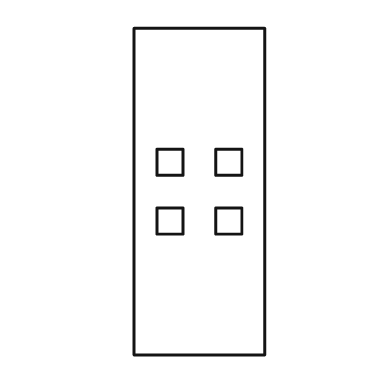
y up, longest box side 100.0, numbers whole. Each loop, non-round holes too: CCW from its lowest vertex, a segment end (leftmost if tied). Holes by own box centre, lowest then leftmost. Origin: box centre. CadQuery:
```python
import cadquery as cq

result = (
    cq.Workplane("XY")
    .moveTo(-20.0, -50.0)
    .lineTo(20.0, -50.0)
    .lineTo(20.0, 50.0)
    .lineTo(-20.0, 50.0)
    .close()
    .moveTo(-13.0, -13.0)
    .lineTo(-5.0, -13.0)
    .lineTo(-5.0, -5.0)
    .lineTo(-13.0, -5.0)
    .close()
    .moveTo(5.0, -13.0)
    .lineTo(13.0, -13.0)
    .lineTo(13.0, -5.0)
    .lineTo(5.0, -5.0)
    .close()
    .moveTo(-13.0, 5.0)
    .lineTo(-5.0, 5.0)
    .lineTo(-5.0, 13.0)
    .lineTo(-13.0, 13.0)
    .close()
    .moveTo(5.0, 5.0)
    .lineTo(13.0, 5.0)
    .lineTo(13.0, 13.0)
    .lineTo(5.0, 13.0)
    .close()
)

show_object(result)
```